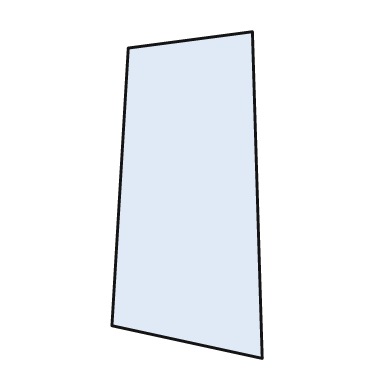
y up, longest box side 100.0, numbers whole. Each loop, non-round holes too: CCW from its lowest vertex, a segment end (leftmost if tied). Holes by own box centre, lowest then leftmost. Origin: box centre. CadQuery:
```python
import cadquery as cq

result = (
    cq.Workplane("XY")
    .moveTo(23.0, -50.0)
    .lineTo(20.0, 50.0)
    .lineTo(-18.0, 45.0)
    .lineTo(-23.0, -40.0)
    .close()
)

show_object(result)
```